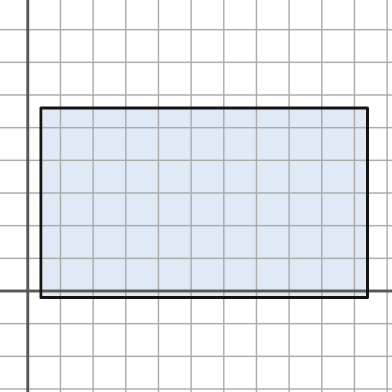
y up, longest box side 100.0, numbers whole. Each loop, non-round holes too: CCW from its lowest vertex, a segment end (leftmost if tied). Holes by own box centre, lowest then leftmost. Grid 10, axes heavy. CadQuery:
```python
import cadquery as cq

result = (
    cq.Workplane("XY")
    .moveTo(4.0, -2.0)
    .lineTo(104.0, -2.0)
    .lineTo(104.0, 56.0)
    .lineTo(4.0, 56.0)
    .close()
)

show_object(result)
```